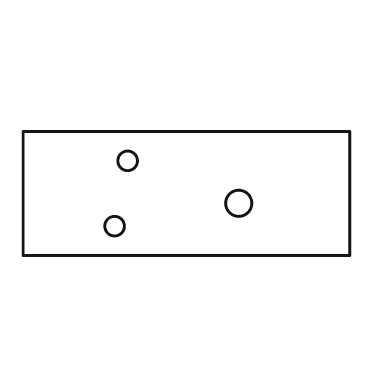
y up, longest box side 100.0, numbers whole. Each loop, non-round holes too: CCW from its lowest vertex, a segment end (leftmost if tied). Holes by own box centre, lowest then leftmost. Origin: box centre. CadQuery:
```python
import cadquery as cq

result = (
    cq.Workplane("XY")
    .moveTo(-50.0, -19.0)
    .lineTo(50.0, -19.0)
    .lineTo(50.0, 19.0)
    .lineTo(-50.0, 19.0)
    .close()
    .moveTo(-22.0, -10.0)
    .circle(3.0)
    .moveTo(16.0, -3.0)
    .circle(4.0)
    .moveTo(-18.0, 10.0)
    .circle(3.0)
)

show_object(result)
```